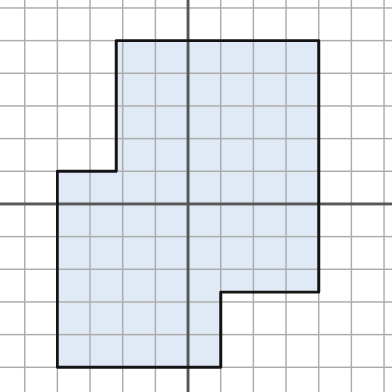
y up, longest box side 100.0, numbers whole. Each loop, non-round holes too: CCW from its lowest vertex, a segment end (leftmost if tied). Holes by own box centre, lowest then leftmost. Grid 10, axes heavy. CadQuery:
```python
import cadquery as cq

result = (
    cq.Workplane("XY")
    .moveTo(-40.0, -50.0)
    .lineTo(10.0, -50.0)
    .lineTo(10.0, -27.0)
    .lineTo(40.0, -27.0)
    .lineTo(40.0, 50.0)
    .lineTo(-22.0, 50.0)
    .lineTo(-22.0, 10.0)
    .lineTo(-40.0, 10.0)
    .close()
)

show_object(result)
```